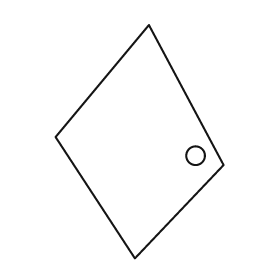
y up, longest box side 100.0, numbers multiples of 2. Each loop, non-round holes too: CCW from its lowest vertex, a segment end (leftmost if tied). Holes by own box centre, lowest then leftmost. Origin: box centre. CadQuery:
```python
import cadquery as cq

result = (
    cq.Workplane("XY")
    .moveTo(-2.0, -50.0)
    .lineTo(36.0, -10.0)
    .lineTo(4.0, 50.0)
    .lineTo(-36.0, 2.0)
    .close()
    .moveTo(24.0, -6.0)
    .circle(4.0)
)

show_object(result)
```